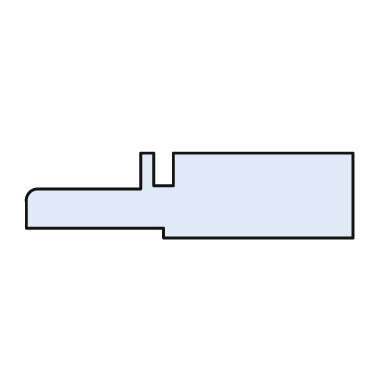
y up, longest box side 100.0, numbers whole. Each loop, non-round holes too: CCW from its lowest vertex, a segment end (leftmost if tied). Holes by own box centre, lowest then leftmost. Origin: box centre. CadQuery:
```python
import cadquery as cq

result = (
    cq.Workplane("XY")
    .moveTo(-8.0, -13.0)
    .lineTo(50.0, -13.0)
    .lineTo(50.0, 13.0)
    .lineTo(-5.0, 13.0)
    .lineTo(-5.0, 3.0)
    .lineTo(-11.0, 3.0)
    .lineTo(-11.0, 13.0)
    .lineTo(-15.0, 13.0)
    .lineTo(-15.0, 2.0)
    .lineTo(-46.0, 2.0)
    .threePointArc((-49.0, 1.0), (-50.0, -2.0))
    .lineTo(-50.0, -10.0)
    .lineTo(-8.0, -10.0)
    .close()
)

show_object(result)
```